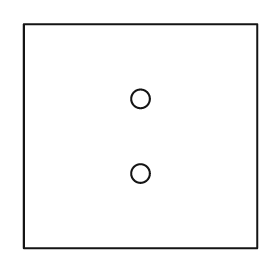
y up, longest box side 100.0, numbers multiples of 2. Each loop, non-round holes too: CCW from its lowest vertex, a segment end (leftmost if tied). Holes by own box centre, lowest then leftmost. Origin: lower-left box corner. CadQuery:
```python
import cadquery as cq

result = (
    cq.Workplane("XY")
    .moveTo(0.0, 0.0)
    .lineTo(100.0, 0.0)
    .lineTo(100.0, 96.0)
    .lineTo(0.0, 96.0)
    .close()
    .moveTo(50.0, 32.0)
    .circle(4.0)
    .moveTo(50.0, 64.0)
    .circle(4.0)
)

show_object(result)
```